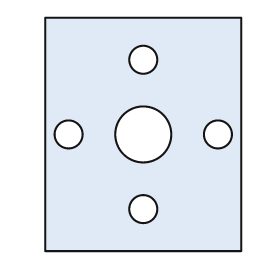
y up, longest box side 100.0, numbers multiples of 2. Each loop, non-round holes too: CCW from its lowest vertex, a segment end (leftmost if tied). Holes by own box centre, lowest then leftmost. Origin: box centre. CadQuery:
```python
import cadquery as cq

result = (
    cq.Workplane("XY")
    .moveTo(-42.0, -50.0)
    .lineTo(42.0, -50.0)
    .lineTo(42.0, 50.0)
    .lineTo(-42.0, 50.0)
    .close()
    .moveTo(0.0, -32.0)
    .circle(6.0)
    .moveTo(-32.0, 0.0)
    .circle(6.0)
    .moveTo(0.0, 0.0)
    .circle(12.0)
    .moveTo(32.0, 0.0)
    .circle(6.0)
    .moveTo(0.0, 32.0)
    .circle(6.0)
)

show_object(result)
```